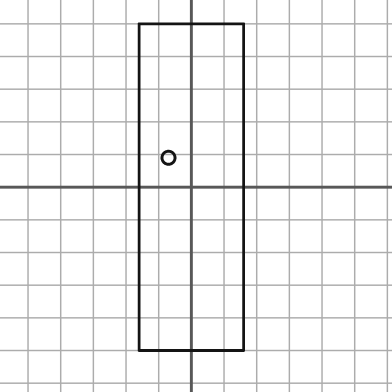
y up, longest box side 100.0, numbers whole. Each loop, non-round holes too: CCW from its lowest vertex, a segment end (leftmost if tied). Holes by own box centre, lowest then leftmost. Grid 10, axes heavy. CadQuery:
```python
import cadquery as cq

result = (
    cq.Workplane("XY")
    .moveTo(-16.0, -50.0)
    .lineTo(16.0, -50.0)
    .lineTo(16.0, 50.0)
    .lineTo(-16.0, 50.0)
    .close()
    .moveTo(-7.0, 9.0)
    .circle(2.0)
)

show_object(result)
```